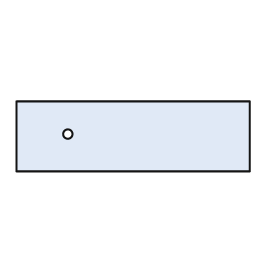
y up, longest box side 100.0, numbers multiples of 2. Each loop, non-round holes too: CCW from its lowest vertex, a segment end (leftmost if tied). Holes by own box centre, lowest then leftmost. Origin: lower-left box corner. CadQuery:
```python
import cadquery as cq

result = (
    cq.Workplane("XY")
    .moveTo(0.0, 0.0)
    .lineTo(100.0, 0.0)
    .lineTo(100.0, 30.0)
    .lineTo(0.0, 30.0)
    .close()
    .moveTo(22.0, 16.0)
    .circle(2.0)
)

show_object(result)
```